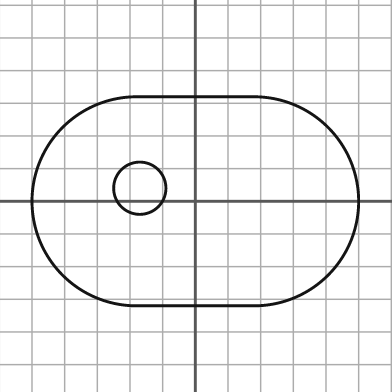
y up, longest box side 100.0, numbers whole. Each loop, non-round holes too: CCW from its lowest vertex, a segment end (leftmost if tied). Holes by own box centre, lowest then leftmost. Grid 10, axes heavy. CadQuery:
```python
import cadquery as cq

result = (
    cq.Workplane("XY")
    .moveTo(-18.0, -32.0)
    .lineTo(18.0, -32.0)
    .threePointArc((50.0, 0.0), (18.0, 32.0))
    .lineTo(-18.0, 32.0)
    .threePointArc((-50.0, 0.0), (-18.0, -32.0))
    .close()
    .moveTo(-17.0, 4.0)
    .circle(8.0)
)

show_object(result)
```